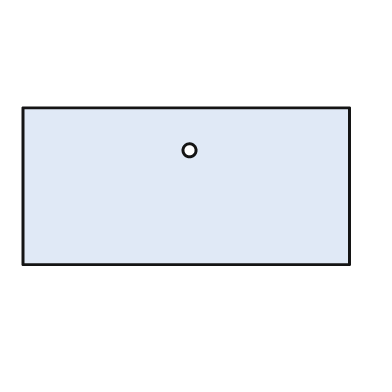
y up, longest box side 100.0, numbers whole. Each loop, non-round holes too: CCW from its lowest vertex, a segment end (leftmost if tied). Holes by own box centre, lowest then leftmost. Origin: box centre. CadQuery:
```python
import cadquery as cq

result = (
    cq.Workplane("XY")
    .moveTo(-50.0, -24.0)
    .lineTo(50.0, -24.0)
    .lineTo(50.0, 24.0)
    .lineTo(-50.0, 24.0)
    .close()
    .moveTo(1.0, 11.0)
    .circle(2.0)
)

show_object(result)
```